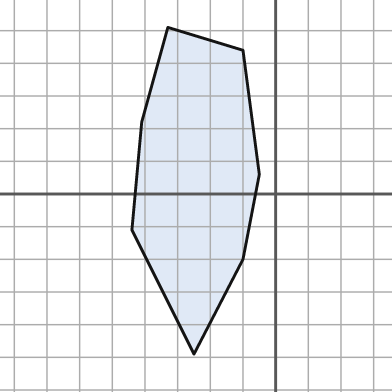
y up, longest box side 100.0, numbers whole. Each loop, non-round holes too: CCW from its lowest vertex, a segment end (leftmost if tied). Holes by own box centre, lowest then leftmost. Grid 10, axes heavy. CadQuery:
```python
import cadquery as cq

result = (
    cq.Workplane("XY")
    .moveTo(-25.0, -49.0)
    .lineTo(-10.0, -20.0)
    .lineTo(-5.0, 6.0)
    .lineTo(-10.0, 44.0)
    .lineTo(-33.0, 51.0)
    .lineTo(-41.0, 22.0)
    .lineTo(-44.0, -11.0)
    .close()
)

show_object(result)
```